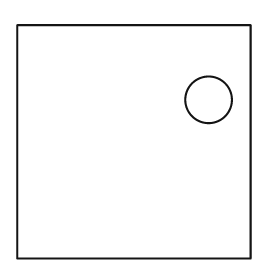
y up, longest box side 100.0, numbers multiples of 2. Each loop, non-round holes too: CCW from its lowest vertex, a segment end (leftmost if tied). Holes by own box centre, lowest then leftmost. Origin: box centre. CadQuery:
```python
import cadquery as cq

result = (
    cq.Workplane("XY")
    .moveTo(-50.0, -50.0)
    .lineTo(50.0, -50.0)
    .lineTo(50.0, 50.0)
    .lineTo(-50.0, 50.0)
    .close()
    .moveTo(32.0, 18.0)
    .circle(10.0)
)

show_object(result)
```